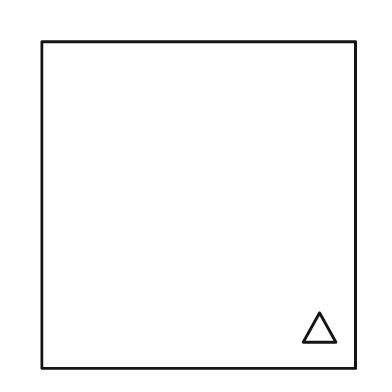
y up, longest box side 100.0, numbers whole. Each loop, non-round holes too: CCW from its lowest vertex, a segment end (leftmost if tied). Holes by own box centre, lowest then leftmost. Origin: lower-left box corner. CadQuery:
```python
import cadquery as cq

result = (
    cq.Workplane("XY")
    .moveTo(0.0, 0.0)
    .lineTo(96.0, 0.0)
    .lineTo(96.0, 100.0)
    .lineTo(0.0, 100.0)
    .close()
    .moveTo(80.0, 8.0)
    .lineTo(90.0, 8.0)
    .lineTo(85.0, 17.0)
    .close()
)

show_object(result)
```